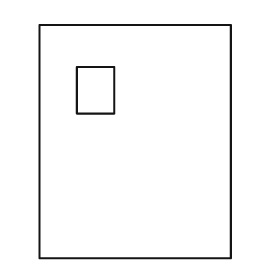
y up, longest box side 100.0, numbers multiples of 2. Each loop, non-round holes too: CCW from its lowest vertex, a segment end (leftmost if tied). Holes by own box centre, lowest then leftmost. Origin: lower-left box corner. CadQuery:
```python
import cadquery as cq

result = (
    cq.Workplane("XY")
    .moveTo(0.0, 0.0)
    .lineTo(82.0, 0.0)
    .lineTo(82.0, 100.0)
    .lineTo(0.0, 100.0)
    .close()
    .moveTo(16.0, 62.0)
    .lineTo(32.0, 62.0)
    .lineTo(32.0, 82.0)
    .lineTo(16.0, 82.0)
    .close()
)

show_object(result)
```